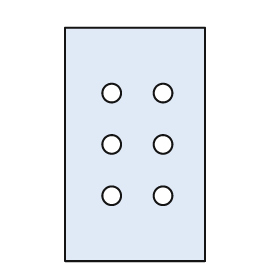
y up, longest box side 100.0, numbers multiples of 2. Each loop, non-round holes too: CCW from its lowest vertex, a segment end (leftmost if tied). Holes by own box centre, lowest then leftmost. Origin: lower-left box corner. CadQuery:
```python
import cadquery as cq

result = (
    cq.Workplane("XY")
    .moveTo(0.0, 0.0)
    .lineTo(60.0, 0.0)
    .lineTo(60.0, 100.0)
    .lineTo(0.0, 100.0)
    .close()
    .moveTo(20.0, 28.0)
    .circle(4.0)
    .moveTo(42.0, 28.0)
    .circle(4.0)
    .moveTo(20.0, 50.0)
    .circle(4.0)
    .moveTo(42.0, 50.0)
    .circle(4.0)
    .moveTo(20.0, 72.0)
    .circle(4.0)
    .moveTo(42.0, 72.0)
    .circle(4.0)
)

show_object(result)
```